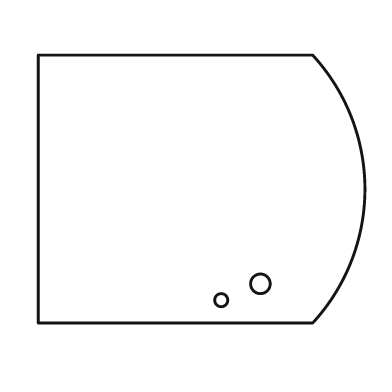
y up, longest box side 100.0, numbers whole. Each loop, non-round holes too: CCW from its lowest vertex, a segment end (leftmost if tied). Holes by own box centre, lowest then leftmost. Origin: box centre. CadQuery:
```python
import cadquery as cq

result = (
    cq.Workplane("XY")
    .moveTo(-50.0, -41.0)
    .lineTo(34.0, -41.0)
    .threePointArc((50.0, 0.0), (34.0, 41.0))
    .lineTo(-50.0, 41.0)
    .close()
    .moveTo(6.0, -34.0)
    .circle(2.0)
    .moveTo(18.0, -29.0)
    .circle(3.0)
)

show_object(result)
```